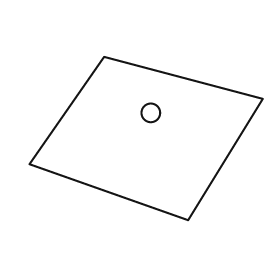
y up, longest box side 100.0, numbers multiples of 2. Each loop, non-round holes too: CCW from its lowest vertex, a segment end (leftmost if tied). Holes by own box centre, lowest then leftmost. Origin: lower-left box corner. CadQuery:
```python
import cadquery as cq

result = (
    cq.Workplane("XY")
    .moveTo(68.0, 0.0)
    .lineTo(100.0, 52.0)
    .lineTo(32.0, 70.0)
    .lineTo(0.0, 24.0)
    .close()
    .moveTo(52.0, 46.0)
    .circle(4.0)
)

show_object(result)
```